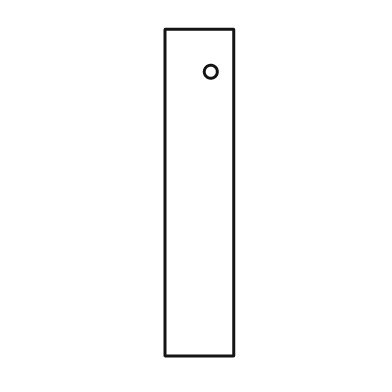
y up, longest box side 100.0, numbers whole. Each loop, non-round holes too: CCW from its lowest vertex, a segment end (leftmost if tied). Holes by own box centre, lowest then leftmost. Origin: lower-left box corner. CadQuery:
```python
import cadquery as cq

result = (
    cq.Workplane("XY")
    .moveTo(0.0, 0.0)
    .lineTo(21.0, 0.0)
    .lineTo(21.0, 100.0)
    .lineTo(0.0, 100.0)
    .close()
    .moveTo(14.0, 87.0)
    .circle(2.0)
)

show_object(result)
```